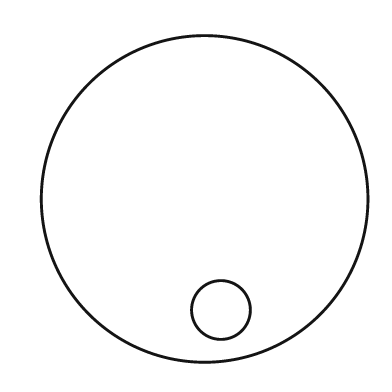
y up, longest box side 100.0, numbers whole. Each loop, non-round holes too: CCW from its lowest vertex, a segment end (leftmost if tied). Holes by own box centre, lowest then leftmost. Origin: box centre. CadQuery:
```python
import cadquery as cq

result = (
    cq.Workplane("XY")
    .moveTo(0.0, 0.0)
    .circle(50.0)
    .moveTo(5.0, -34.0)
    .circle(9.0)
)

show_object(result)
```